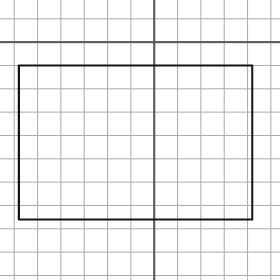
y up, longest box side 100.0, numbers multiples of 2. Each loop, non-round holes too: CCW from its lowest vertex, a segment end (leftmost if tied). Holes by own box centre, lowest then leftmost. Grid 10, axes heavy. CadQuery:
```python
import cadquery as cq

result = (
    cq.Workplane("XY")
    .moveTo(-58.0, -76.0)
    .lineTo(42.0, -76.0)
    .lineTo(42.0, -10.0)
    .lineTo(-58.0, -10.0)
    .close()
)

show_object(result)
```